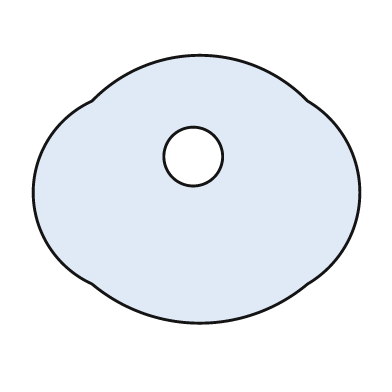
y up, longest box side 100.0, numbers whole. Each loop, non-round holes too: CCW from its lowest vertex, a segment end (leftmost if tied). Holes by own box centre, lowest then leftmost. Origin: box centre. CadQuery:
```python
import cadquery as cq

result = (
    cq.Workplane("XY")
    .moveTo(-32.0, -29.0)
    .threePointArc((1.0, -41.0), (34.0, -29.0))
    .threePointArc((50.0, -1.0), (34.0, 27.0))
    .threePointArc((1.0, 41.0), (-32.0, 27.0))
    .threePointArc((-50.0, -1.0), (-32.0, -29.0))
    .close()
    .moveTo(-1.0, 10.0)
    .circle(9.0)
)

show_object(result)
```